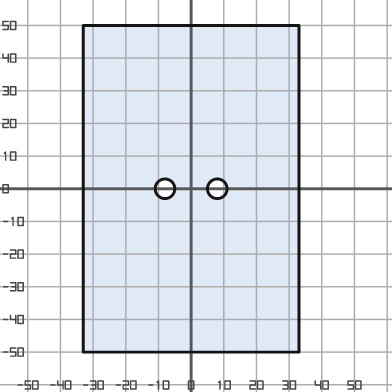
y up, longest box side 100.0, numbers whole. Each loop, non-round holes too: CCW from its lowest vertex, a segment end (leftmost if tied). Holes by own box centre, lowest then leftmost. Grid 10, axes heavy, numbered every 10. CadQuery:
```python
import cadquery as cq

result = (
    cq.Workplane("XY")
    .moveTo(-33.0, -50.0)
    .lineTo(33.0, -50.0)
    .lineTo(33.0, 50.0)
    .lineTo(-33.0, 50.0)
    .close()
    .moveTo(-8.0, 0.0)
    .circle(3.0)
    .moveTo(8.0, 0.0)
    .circle(3.0)
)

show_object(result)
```